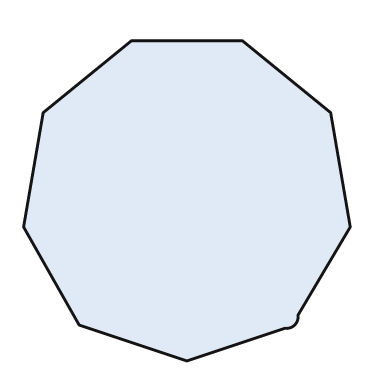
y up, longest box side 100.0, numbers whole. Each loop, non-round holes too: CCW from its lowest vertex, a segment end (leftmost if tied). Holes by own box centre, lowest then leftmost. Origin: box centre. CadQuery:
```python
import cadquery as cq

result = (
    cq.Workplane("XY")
    .moveTo(0.0, -49.0)
    .lineTo(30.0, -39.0)
    .threePointArc((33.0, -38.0), (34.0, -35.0))
    .lineTo(50.0, -8.0)
    .lineTo(44.0, 27.0)
    .lineTo(17.0, 49.0)
    .lineTo(-17.0, 49.0)
    .lineTo(-44.0, 27.0)
    .lineTo(-50.0, -8.0)
    .lineTo(-33.0, -38.0)
    .close()
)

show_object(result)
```